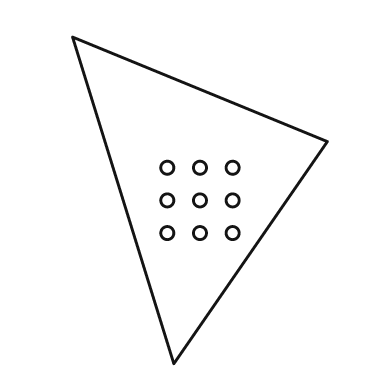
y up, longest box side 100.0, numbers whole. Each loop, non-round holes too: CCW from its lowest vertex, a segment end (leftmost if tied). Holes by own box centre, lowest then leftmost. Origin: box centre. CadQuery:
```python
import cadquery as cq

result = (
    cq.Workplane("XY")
    .moveTo(-8.0, -50.0)
    .lineTo(39.0, 18.0)
    .lineTo(-39.0, 50.0)
    .close()
    .moveTo(-10.0, -10.0)
    .circle(2.0)
    .moveTo(0.0, -10.0)
    .circle(2.0)
    .moveTo(10.0, -10.0)
    .circle(2.0)
    .moveTo(-10.0, 0.0)
    .circle(2.0)
    .moveTo(0.0, 0.0)
    .circle(2.0)
    .moveTo(10.0, 0.0)
    .circle(2.0)
    .moveTo(-10.0, 10.0)
    .circle(2.0)
    .moveTo(0.0, 10.0)
    .circle(2.0)
    .moveTo(10.0, 10.0)
    .circle(2.0)
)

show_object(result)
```